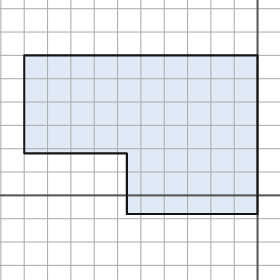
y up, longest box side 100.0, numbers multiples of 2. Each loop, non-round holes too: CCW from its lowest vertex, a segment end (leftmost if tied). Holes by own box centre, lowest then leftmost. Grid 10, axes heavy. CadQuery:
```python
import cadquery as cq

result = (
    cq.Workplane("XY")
    .moveTo(-56.0, -8.0)
    .lineTo(0.0, -8.0)
    .lineTo(0.0, 60.0)
    .lineTo(-100.0, 60.0)
    .lineTo(-100.0, 18.0)
    .lineTo(-56.0, 18.0)
    .close()
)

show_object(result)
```